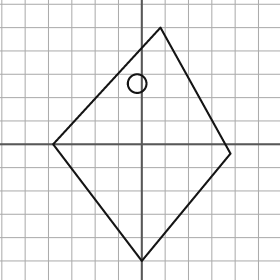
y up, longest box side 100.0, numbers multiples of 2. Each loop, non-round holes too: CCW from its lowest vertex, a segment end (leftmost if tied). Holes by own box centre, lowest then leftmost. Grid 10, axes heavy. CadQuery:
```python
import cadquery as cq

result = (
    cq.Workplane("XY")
    .moveTo(0.0, -50.0)
    .lineTo(38.0, -4.0)
    .lineTo(8.0, 50.0)
    .lineTo(-38.0, 0.0)
    .close()
    .moveTo(-2.0, 26.0)
    .circle(4.0)
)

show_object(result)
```